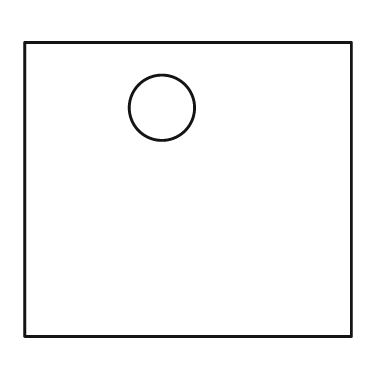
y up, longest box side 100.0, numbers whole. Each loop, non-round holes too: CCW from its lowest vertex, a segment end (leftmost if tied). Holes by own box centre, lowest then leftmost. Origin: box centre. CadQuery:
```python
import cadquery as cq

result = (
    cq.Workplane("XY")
    .moveTo(-50.0, -45.0)
    .lineTo(50.0, -45.0)
    .lineTo(50.0, 45.0)
    .lineTo(-50.0, 45.0)
    .close()
    .moveTo(-8.0, 25.0)
    .circle(10.0)
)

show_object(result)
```